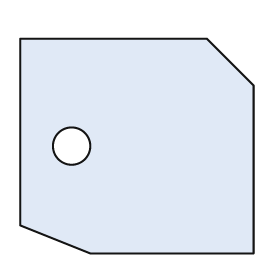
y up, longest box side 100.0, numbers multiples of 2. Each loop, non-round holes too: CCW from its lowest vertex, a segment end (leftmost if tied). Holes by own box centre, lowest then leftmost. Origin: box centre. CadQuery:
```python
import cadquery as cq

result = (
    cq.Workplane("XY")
    .moveTo(-20.0, -46.0)
    .lineTo(50.0, -46.0)
    .lineTo(50.0, 26.0)
    .lineTo(30.0, 46.0)
    .lineTo(-50.0, 46.0)
    .lineTo(-50.0, -34.0)
    .close()
    .moveTo(-28.0, 0.0)
    .circle(8.0)
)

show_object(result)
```